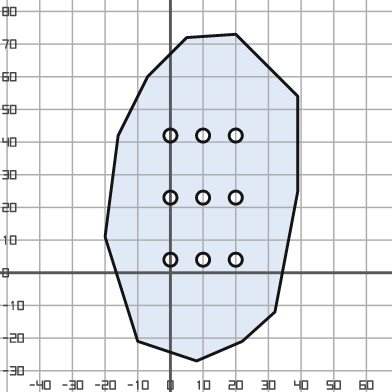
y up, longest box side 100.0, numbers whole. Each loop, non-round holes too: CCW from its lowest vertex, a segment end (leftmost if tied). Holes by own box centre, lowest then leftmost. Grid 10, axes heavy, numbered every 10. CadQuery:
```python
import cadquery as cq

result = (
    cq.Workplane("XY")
    .moveTo(8.0, -27.0)
    .lineTo(22.0, -21.0)
    .lineTo(32.0, -12.0)
    .lineTo(39.0, 25.0)
    .lineTo(39.0, 54.0)
    .lineTo(20.0, 73.0)
    .lineTo(5.0, 72.0)
    .lineTo(-7.0, 60.0)
    .lineTo(-16.0, 42.0)
    .lineTo(-20.0, 11.0)
    .lineTo(-10.0, -21.0)
    .close()
    .moveTo(0.0, 4.0)
    .circle(2.0)
    .moveTo(10.0, 4.0)
    .circle(2.0)
    .moveTo(20.0, 4.0)
    .circle(2.0)
    .moveTo(0.0, 23.0)
    .circle(2.0)
    .moveTo(10.0, 23.0)
    .circle(2.0)
    .moveTo(20.0, 23.0)
    .circle(2.0)
    .moveTo(0.0, 42.0)
    .circle(2.0)
    .moveTo(10.0, 42.0)
    .circle(2.0)
    .moveTo(20.0, 42.0)
    .circle(2.0)
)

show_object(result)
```